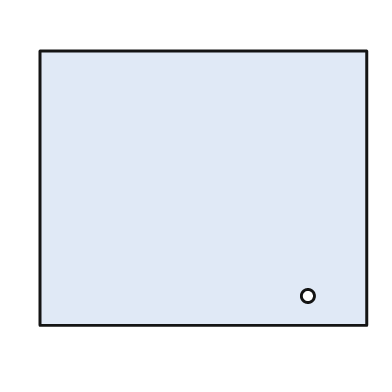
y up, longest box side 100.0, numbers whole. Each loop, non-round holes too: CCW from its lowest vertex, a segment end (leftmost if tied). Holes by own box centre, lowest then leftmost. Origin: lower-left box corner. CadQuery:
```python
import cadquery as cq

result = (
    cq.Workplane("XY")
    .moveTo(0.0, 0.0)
    .lineTo(100.0, 0.0)
    .lineTo(100.0, 84.0)
    .lineTo(0.0, 84.0)
    .close()
    .moveTo(82.0, 9.0)
    .circle(2.0)
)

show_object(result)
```